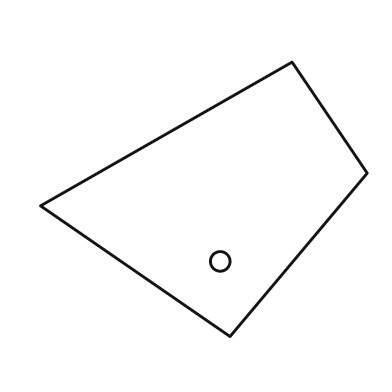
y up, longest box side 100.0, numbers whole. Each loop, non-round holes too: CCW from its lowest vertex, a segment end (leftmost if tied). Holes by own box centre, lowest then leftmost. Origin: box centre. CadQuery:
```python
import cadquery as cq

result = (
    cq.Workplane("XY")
    .moveTo(8.0, -42.0)
    .lineTo(50.0, 8.0)
    .lineTo(27.0, 42.0)
    .lineTo(-50.0, -2.0)
    .close()
    .moveTo(5.0, -19.0)
    .circle(3.0)
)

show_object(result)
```